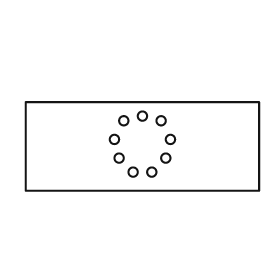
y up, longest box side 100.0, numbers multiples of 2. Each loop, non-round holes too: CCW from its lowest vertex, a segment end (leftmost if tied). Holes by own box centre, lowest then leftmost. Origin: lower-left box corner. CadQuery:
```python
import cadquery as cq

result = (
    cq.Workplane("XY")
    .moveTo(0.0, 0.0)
    .lineTo(100.0, 0.0)
    .lineTo(100.0, 38.0)
    .lineTo(0.0, 38.0)
    .close()
    .moveTo(46.0, 8.0)
    .circle(2.0)
    .moveTo(54.0, 8.0)
    .circle(2.0)
    .moveTo(40.0, 14.0)
    .circle(2.0)
    .moveTo(60.0, 14.0)
    .circle(2.0)
    .moveTo(38.0, 22.0)
    .circle(2.0)
    .moveTo(62.0, 22.0)
    .circle(2.0)
    .moveTo(42.0, 30.0)
    .circle(2.0)
    .moveTo(58.0, 30.0)
    .circle(2.0)
    .moveTo(50.0, 32.0)
    .circle(2.0)
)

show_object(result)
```